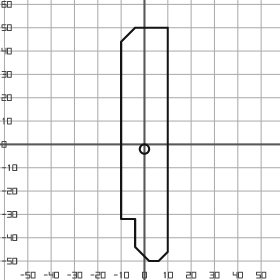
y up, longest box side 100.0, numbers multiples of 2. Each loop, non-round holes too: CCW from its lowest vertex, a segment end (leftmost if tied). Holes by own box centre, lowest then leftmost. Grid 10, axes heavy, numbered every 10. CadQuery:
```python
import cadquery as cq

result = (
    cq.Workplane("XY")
    .moveTo(2.0, -50.0)
    .lineTo(6.0, -50.0)
    .lineTo(10.0, -46.0)
    .lineTo(10.0, 50.0)
    .lineTo(-4.0, 50.0)
    .lineTo(-10.0, 44.0)
    .lineTo(-10.0, -32.0)
    .lineTo(-4.0, -32.0)
    .lineTo(-4.0, -44.0)
    .close()
    .moveTo(0.0, -2.0)
    .circle(2.0)
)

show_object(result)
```